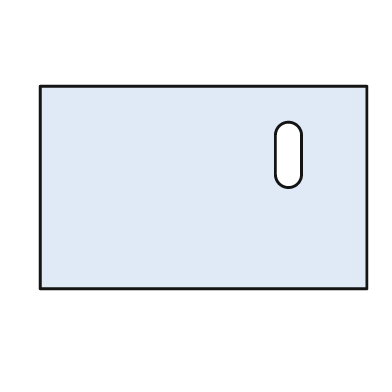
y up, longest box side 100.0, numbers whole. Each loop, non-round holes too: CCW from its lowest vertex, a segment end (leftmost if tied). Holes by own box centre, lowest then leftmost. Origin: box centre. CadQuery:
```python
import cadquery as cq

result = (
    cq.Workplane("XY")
    .moveTo(-50.0, -31.0)
    .lineTo(50.0, -31.0)
    .lineTo(50.0, 31.0)
    .lineTo(-50.0, 31.0)
    .close()
    .moveTo(22.0, 4.0)
    .threePointArc((26.0, 0.0), (30.0, 4.0))
    .lineTo(30.0, 16.0)
    .threePointArc((26.0, 20.0), (22.0, 16.0))
    .close()
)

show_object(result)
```